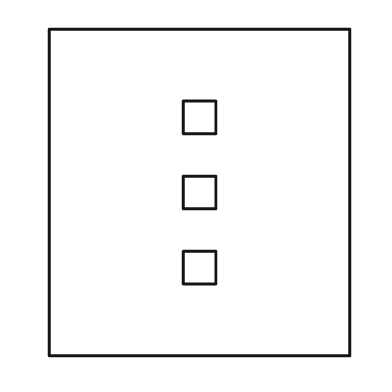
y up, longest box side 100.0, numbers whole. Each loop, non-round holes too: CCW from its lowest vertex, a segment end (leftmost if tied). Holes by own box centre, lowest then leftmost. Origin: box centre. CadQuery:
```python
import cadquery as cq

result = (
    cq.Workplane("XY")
    .moveTo(-46.0, -50.0)
    .lineTo(46.0, -50.0)
    .lineTo(46.0, 50.0)
    .lineTo(-46.0, 50.0)
    .close()
    .moveTo(-5.0, -28.0)
    .lineTo(5.0, -28.0)
    .lineTo(5.0, -18.0)
    .lineTo(-5.0, -18.0)
    .close()
    .moveTo(-5.0, -5.0)
    .lineTo(5.0, -5.0)
    .lineTo(5.0, 5.0)
    .lineTo(-5.0, 5.0)
    .close()
    .moveTo(-5.0, 18.0)
    .lineTo(5.0, 18.0)
    .lineTo(5.0, 28.0)
    .lineTo(-5.0, 28.0)
    .close()
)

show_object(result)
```